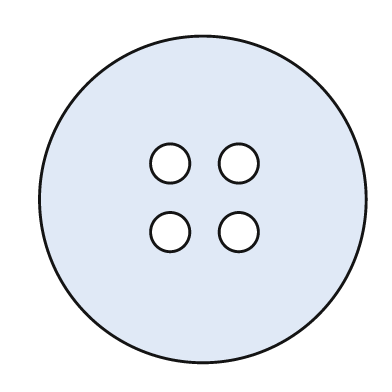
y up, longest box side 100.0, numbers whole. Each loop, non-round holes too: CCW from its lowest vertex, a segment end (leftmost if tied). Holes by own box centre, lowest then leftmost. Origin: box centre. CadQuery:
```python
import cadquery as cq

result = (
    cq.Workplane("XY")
    .moveTo(0.0, 0.0)
    .circle(50.0)
    .moveTo(-10.0, -10.0)
    .circle(6.0)
    .moveTo(11.0, -10.0)
    .circle(6.0)
    .moveTo(-10.0, 11.0)
    .circle(6.0)
    .moveTo(11.0, 11.0)
    .circle(6.0)
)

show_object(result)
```